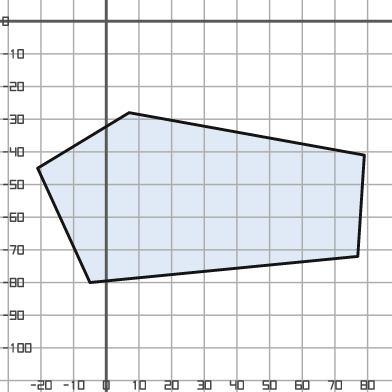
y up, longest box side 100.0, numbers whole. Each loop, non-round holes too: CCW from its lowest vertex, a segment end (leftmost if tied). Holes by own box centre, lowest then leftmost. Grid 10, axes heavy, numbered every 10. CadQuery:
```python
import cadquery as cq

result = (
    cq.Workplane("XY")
    .moveTo(-5.0, -80.0)
    .lineTo(77.0, -72.0)
    .lineTo(79.0, -41.0)
    .lineTo(7.0, -28.0)
    .lineTo(-21.0, -45.0)
    .close()
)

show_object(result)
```